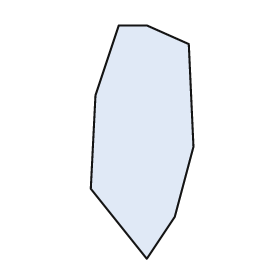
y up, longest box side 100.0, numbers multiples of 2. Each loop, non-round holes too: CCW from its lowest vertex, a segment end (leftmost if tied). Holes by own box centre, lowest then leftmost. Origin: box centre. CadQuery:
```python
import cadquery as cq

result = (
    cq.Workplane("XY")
    .moveTo(2.0, -50.0)
    .lineTo(14.0, -32.0)
    .lineTo(22.0, -2.0)
    .lineTo(20.0, 42.0)
    .lineTo(2.0, 50.0)
    .lineTo(-10.0, 50.0)
    .lineTo(-20.0, 20.0)
    .lineTo(-22.0, -20.0)
    .close()
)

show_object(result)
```